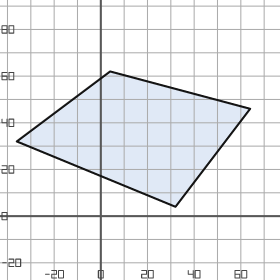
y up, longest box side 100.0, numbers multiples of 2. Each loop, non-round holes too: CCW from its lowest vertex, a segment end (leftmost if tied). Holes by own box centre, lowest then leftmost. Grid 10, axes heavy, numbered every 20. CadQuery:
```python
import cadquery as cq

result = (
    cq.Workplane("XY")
    .moveTo(32.0, 4.0)
    .lineTo(64.0, 46.0)
    .lineTo(4.0, 62.0)
    .lineTo(-36.0, 32.0)
    .close()
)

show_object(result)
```